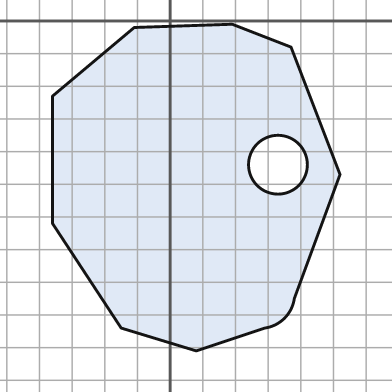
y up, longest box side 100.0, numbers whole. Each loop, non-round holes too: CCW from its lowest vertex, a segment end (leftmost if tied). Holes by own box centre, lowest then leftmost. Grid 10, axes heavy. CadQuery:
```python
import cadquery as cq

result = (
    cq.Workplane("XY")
    .moveTo(8.0, -101.0)
    .lineTo(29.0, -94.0)
    .threePointArc((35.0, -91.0), (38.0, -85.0))
    .lineTo(52.0, -47.0)
    .lineTo(37.0, -8.0)
    .lineTo(19.0, -1.0)
    .lineTo(-11.0, -2.0)
    .lineTo(-36.0, -23.0)
    .lineTo(-36.0, -62.0)
    .lineTo(-15.0, -94.0)
    .close()
    .moveTo(33.0, -44.0)
    .circle(9.0)
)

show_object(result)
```